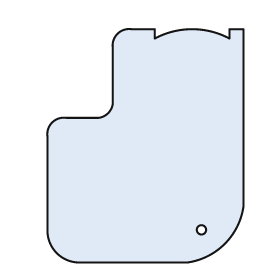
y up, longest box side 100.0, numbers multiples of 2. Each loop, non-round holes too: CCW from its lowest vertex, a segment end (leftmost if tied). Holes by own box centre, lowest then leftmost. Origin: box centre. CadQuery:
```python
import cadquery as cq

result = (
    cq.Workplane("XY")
    .moveTo(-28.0, -50.0)
    .lineTo(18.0, -50.0)
    .threePointArc((34.0, -42.0), (42.0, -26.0))
    .lineTo(42.0, 50.0)
    .lineTo(36.0, 50.0)
    .lineTo(36.0, 46.0)
    .threePointArc((20.0, 50.0), (4.0, 46.0))
    .lineTo(4.0, 50.0)
    .lineTo(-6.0, 50.0)
    .threePointArc((-12.0, 48.0), (-14.0, 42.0))
    .lineTo(-14.0, 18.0)
    .threePointArc((-16.0, 14.0), (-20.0, 12.0))
    .lineTo(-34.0, 12.0)
    .threePointArc((-40.0, 10.0), (-42.0, 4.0))
    .lineTo(-42.0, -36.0)
    .threePointArc((-38.0, -46.0), (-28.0, -50.0))
    .close()
    .moveTo(24.0, -36.0)
    .circle(2.0)
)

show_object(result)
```